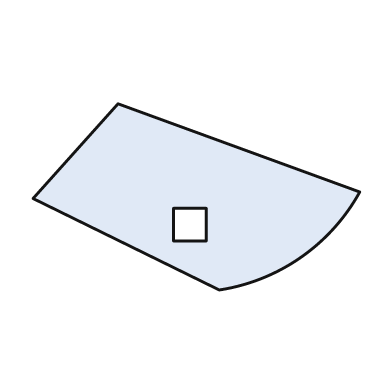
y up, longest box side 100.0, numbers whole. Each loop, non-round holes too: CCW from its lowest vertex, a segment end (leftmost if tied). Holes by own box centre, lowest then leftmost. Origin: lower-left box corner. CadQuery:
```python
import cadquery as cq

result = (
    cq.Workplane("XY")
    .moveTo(57.0, 0.0)
    .threePointArc((82.0, 10.0), (100.0, 30.0))
    .lineTo(26.0, 57.0)
    .lineTo(0.0, 28.0)
    .close()
    .moveTo(43.0, 15.0)
    .lineTo(53.0, 15.0)
    .lineTo(53.0, 25.0)
    .lineTo(43.0, 25.0)
    .close()
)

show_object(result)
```